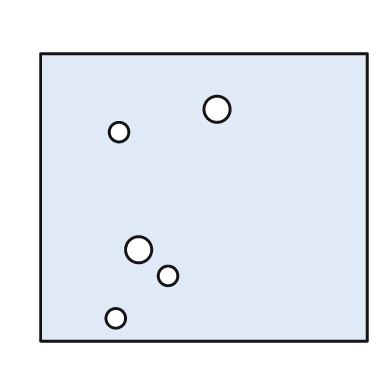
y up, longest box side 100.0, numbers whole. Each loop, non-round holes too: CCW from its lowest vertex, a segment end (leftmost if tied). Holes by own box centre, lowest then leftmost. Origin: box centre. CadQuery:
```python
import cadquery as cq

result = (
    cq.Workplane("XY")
    .moveTo(-50.0, -44.0)
    .lineTo(50.0, -44.0)
    .lineTo(50.0, 44.0)
    .lineTo(-50.0, 44.0)
    .close()
    .moveTo(-27.0, -37.0)
    .circle(3.0)
    .moveTo(-11.0, -24.0)
    .circle(3.0)
    .moveTo(-20.0, -16.0)
    .circle(4.0)
    .moveTo(-26.0, 20.0)
    .circle(3.0)
    .moveTo(4.0, 27.0)
    .circle(4.0)
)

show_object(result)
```